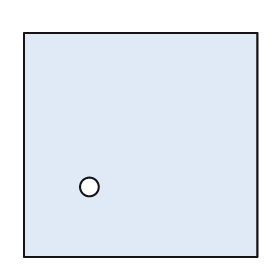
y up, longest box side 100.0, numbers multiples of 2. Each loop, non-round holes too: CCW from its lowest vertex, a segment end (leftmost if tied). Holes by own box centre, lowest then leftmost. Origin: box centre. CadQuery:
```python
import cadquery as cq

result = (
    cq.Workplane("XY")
    .moveTo(-50.0, -48.0)
    .lineTo(50.0, -48.0)
    .lineTo(50.0, 48.0)
    .lineTo(-50.0, 48.0)
    .close()
    .moveTo(-22.0, -18.0)
    .circle(4.0)
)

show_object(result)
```